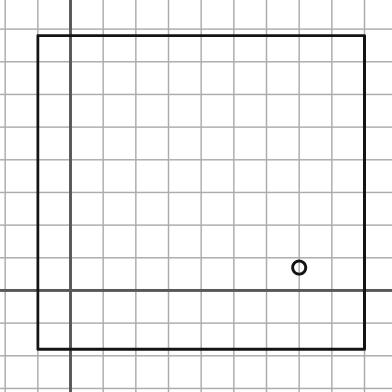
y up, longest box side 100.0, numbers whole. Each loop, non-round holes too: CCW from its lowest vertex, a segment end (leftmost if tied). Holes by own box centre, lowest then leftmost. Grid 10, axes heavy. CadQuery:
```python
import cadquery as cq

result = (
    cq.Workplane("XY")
    .moveTo(-10.0, -18.0)
    .lineTo(90.0, -18.0)
    .lineTo(90.0, 78.0)
    .lineTo(-10.0, 78.0)
    .close()
    .moveTo(70.0, 7.0)
    .circle(2.0)
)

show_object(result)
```